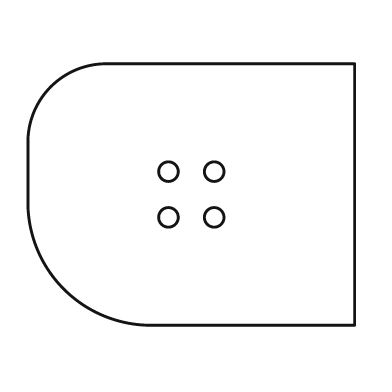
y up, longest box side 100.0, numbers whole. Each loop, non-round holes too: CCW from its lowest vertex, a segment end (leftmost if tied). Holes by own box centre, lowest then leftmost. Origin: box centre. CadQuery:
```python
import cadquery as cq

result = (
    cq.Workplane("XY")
    .moveTo(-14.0, -40.0)
    .lineTo(50.0, -40.0)
    .lineTo(50.0, 40.0)
    .lineTo(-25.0, 40.0)
    .threePointArc((-43.0, 33.0), (-50.0, 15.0))
    .lineTo(-50.0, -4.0)
    .threePointArc((-39.0, -29.0), (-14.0, -40.0))
    .close()
    .moveTo(-7.0, -7.0)
    .circle(3.0)
    .moveTo(7.0, -7.0)
    .circle(3.0)
    .moveTo(-7.0, 7.0)
    .circle(3.0)
    .moveTo(7.0, 7.0)
    .circle(3.0)
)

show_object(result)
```